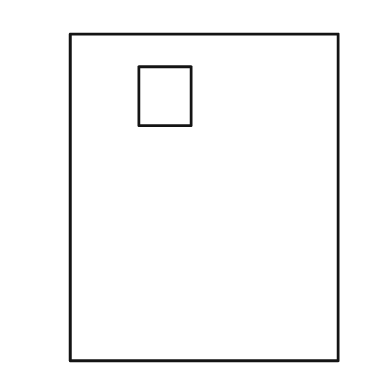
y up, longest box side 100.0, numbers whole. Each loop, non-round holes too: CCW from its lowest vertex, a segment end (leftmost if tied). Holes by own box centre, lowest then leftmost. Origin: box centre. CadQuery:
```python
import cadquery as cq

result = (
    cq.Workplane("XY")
    .moveTo(-41.0, -50.0)
    .lineTo(41.0, -50.0)
    .lineTo(41.0, 50.0)
    .lineTo(-41.0, 50.0)
    .close()
    .moveTo(-20.0, 22.0)
    .lineTo(-4.0, 22.0)
    .lineTo(-4.0, 40.0)
    .lineTo(-20.0, 40.0)
    .close()
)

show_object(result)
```